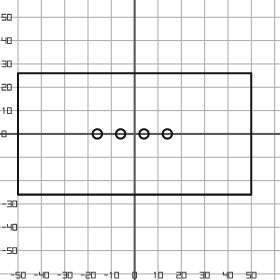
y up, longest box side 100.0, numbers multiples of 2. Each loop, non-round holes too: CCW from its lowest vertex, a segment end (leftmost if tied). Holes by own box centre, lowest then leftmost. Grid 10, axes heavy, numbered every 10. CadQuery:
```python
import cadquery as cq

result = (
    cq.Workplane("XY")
    .moveTo(-50.0, -26.0)
    .lineTo(50.0, -26.0)
    .lineTo(50.0, 26.0)
    .lineTo(-50.0, 26.0)
    .close()
    .moveTo(-16.0, 0.0)
    .circle(2.0)
    .moveTo(-6.0, 0.0)
    .circle(2.0)
    .moveTo(4.0, 0.0)
    .circle(2.0)
    .moveTo(14.0, 0.0)
    .circle(2.0)
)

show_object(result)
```